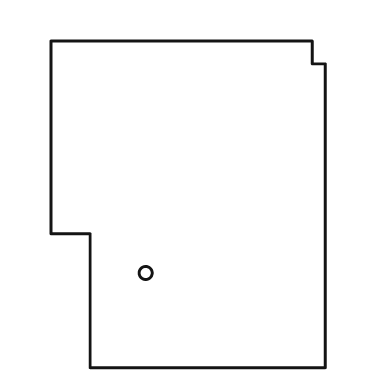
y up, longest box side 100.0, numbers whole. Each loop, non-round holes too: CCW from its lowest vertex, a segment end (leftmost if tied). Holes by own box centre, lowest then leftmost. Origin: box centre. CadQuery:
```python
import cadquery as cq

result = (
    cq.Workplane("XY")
    .moveTo(-30.0, -50.0)
    .lineTo(42.0, -50.0)
    .lineTo(42.0, 43.0)
    .lineTo(38.0, 43.0)
    .lineTo(38.0, 50.0)
    .lineTo(-42.0, 50.0)
    .lineTo(-42.0, -9.0)
    .lineTo(-30.0, -9.0)
    .close()
    .moveTo(-13.0, -21.0)
    .circle(2.0)
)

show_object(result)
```